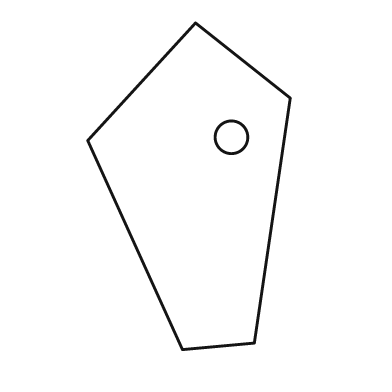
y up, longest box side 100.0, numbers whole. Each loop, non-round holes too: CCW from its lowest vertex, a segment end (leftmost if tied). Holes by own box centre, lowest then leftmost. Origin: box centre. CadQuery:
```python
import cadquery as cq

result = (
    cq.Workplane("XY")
    .moveTo(-2.0, -50.0)
    .lineTo(20.0, -48.0)
    .lineTo(31.0, 27.0)
    .lineTo(2.0, 50.0)
    .lineTo(-31.0, 14.0)
    .close()
    .moveTo(13.0, 15.0)
    .circle(5.0)
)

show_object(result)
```